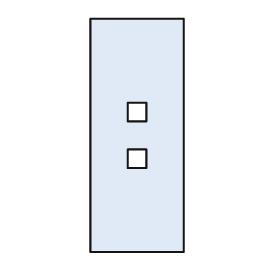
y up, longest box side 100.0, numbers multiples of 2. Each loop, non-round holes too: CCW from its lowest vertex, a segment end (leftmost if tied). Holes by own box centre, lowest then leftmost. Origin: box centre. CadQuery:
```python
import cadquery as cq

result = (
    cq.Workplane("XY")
    .moveTo(-20.0, -50.0)
    .lineTo(20.0, -50.0)
    .lineTo(20.0, 50.0)
    .lineTo(-20.0, 50.0)
    .close()
    .moveTo(-4.0, -14.0)
    .lineTo(4.0, -14.0)
    .lineTo(4.0, -6.0)
    .lineTo(-4.0, -6.0)
    .close()
    .moveTo(-4.0, 6.0)
    .lineTo(4.0, 6.0)
    .lineTo(4.0, 14.0)
    .lineTo(-4.0, 14.0)
    .close()
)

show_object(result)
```